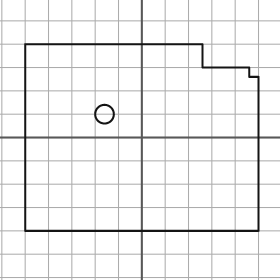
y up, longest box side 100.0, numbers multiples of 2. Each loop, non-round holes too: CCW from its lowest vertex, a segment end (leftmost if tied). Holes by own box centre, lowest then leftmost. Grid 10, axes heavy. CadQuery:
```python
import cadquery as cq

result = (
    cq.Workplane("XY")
    .moveTo(-50.0, -40.0)
    .lineTo(50.0, -40.0)
    .lineTo(50.0, 26.0)
    .lineTo(46.0, 26.0)
    .lineTo(46.0, 30.0)
    .lineTo(26.0, 30.0)
    .lineTo(26.0, 40.0)
    .lineTo(-50.0, 40.0)
    .close()
    .moveTo(-16.0, 10.0)
    .circle(4.0)
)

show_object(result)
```